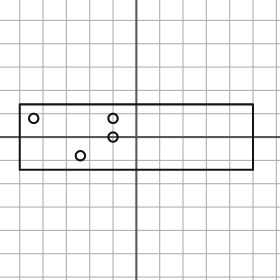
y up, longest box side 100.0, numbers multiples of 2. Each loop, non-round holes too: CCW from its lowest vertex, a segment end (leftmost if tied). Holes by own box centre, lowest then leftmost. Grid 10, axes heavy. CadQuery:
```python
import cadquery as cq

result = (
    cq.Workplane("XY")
    .moveTo(-50.0, -14.0)
    .lineTo(50.0, -14.0)
    .lineTo(50.0, 14.0)
    .lineTo(-50.0, 14.0)
    .close()
    .moveTo(-24.0, -8.0)
    .circle(2.0)
    .moveTo(-10.0, 0.0)
    .circle(2.0)
    .moveTo(-44.0, 8.0)
    .circle(2.0)
    .moveTo(-10.0, 8.0)
    .circle(2.0)
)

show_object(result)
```